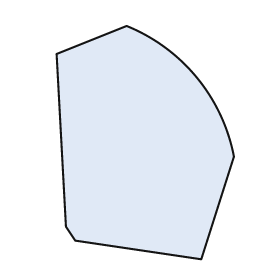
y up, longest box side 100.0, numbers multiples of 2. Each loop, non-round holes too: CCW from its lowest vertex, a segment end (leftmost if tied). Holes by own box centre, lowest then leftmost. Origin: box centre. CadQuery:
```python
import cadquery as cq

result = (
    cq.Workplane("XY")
    .moveTo(24.0, -50.0)
    .lineTo(38.0, -6.0)
    .threePointArc((22.0, 28.0), (-8.0, 50.0))
    .lineTo(-38.0, 38.0)
    .lineTo(-34.0, -36.0)
    .lineTo(-30.0, -42.0)
    .close()
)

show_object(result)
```